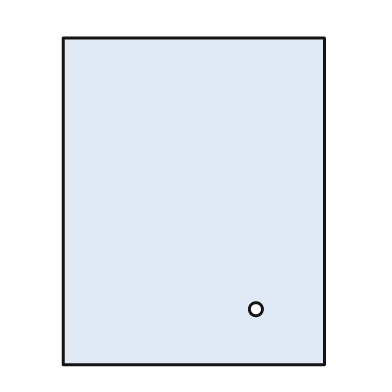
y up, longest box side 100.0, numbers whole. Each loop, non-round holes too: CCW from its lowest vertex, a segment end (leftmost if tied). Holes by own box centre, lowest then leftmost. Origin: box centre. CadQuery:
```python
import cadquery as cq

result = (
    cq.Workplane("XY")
    .moveTo(-40.0, -50.0)
    .lineTo(40.0, -50.0)
    .lineTo(40.0, 50.0)
    .lineTo(-40.0, 50.0)
    .close()
    .moveTo(19.0, -33.0)
    .circle(2.0)
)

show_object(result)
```